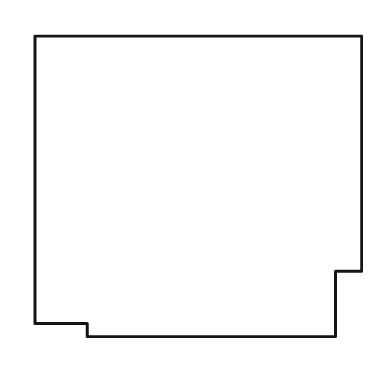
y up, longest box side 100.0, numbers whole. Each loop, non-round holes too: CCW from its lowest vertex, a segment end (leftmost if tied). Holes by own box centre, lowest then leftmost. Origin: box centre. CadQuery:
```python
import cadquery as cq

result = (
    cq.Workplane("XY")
    .moveTo(-34.0, -46.0)
    .lineTo(42.0, -46.0)
    .lineTo(42.0, -26.0)
    .lineTo(50.0, -26.0)
    .lineTo(50.0, 46.0)
    .lineTo(-50.0, 46.0)
    .lineTo(-50.0, -42.0)
    .lineTo(-34.0, -42.0)
    .close()
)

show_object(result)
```